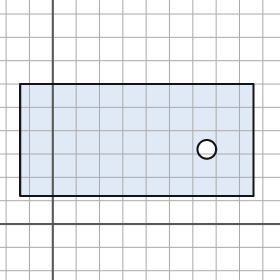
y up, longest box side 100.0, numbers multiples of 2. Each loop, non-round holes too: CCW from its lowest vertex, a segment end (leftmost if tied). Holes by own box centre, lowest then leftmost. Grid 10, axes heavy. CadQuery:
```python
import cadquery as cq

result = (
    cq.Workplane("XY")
    .moveTo(-14.0, 12.0)
    .lineTo(86.0, 12.0)
    .lineTo(86.0, 60.0)
    .lineTo(-14.0, 60.0)
    .close()
    .moveTo(66.0, 32.0)
    .circle(4.0)
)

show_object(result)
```